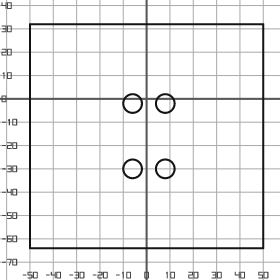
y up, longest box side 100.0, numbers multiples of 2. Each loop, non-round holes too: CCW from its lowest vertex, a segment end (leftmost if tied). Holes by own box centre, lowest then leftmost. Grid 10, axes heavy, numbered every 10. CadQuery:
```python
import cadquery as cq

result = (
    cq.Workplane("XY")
    .moveTo(-50.0, -64.0)
    .lineTo(50.0, -64.0)
    .lineTo(50.0, 32.0)
    .lineTo(-50.0, 32.0)
    .close()
    .moveTo(-6.0, -30.0)
    .circle(4.0)
    .moveTo(8.0, -30.0)
    .circle(4.0)
    .moveTo(-6.0, -2.0)
    .circle(4.0)
    .moveTo(8.0, -2.0)
    .circle(4.0)
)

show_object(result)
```